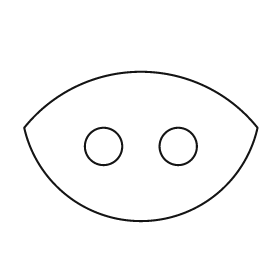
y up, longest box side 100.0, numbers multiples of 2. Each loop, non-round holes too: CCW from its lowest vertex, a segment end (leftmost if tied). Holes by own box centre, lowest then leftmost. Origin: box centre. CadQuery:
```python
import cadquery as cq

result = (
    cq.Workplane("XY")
    .moveTo(-50.0, 8.0)
    .threePointArc((0.0, -32.0), (50.0, 8.0))
    .threePointArc((0.0, 32.0), (-50.0, 8.0))
    .close()
    .moveTo(-16.0, 0.0)
    .circle(8.0)
    .moveTo(16.0, 0.0)
    .circle(8.0)
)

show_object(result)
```